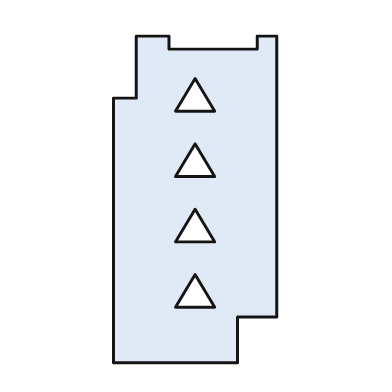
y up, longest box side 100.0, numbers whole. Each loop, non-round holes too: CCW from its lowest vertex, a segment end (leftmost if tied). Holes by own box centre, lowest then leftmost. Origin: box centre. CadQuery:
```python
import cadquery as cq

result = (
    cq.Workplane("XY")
    .moveTo(-25.0, -50.0)
    .lineTo(13.0, -50.0)
    .lineTo(13.0, -36.0)
    .lineTo(25.0, -36.0)
    .lineTo(25.0, 50.0)
    .lineTo(19.0, 50.0)
    .lineTo(19.0, 46.0)
    .lineTo(-8.0, 46.0)
    .lineTo(-8.0, 50.0)
    .lineTo(-18.0, 50.0)
    .lineTo(-18.0, 31.0)
    .lineTo(-25.0, 31.0)
    .close()
    .moveTo(-6.0, -33.0)
    .lineTo(6.0, -33.0)
    .lineTo(0.0, -23.0)
    .close()
    .moveTo(-6.0, -13.0)
    .lineTo(6.0, -13.0)
    .lineTo(0.0, -3.0)
    .close()
    .moveTo(-6.0, 7.0)
    .lineTo(6.0, 7.0)
    .lineTo(0.0, 17.0)
    .close()
    .moveTo(-6.0, 27.0)
    .lineTo(6.0, 27.0)
    .lineTo(0.0, 37.0)
    .close()
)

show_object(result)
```